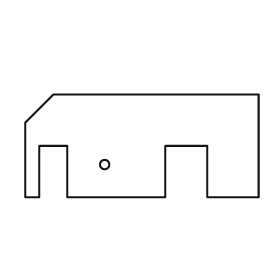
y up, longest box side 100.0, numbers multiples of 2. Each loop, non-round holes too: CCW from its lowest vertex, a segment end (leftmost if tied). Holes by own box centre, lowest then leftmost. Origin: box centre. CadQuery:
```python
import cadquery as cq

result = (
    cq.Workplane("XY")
    .moveTo(-50.0, -22.0)
    .lineTo(-44.0, -22.0)
    .lineTo(-44.0, 0.0)
    .lineTo(-32.0, 0.0)
    .lineTo(-32.0, -22.0)
    .lineTo(10.0, -22.0)
    .lineTo(10.0, 0.0)
    .lineTo(28.0, 0.0)
    .lineTo(28.0, -22.0)
    .lineTo(50.0, -22.0)
    .lineTo(50.0, 22.0)
    .lineTo(-38.0, 22.0)
    .lineTo(-50.0, 10.0)
    .close()
    .moveTo(-16.0, -8.0)
    .circle(2.0)
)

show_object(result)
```